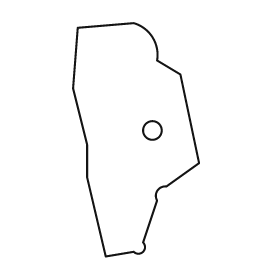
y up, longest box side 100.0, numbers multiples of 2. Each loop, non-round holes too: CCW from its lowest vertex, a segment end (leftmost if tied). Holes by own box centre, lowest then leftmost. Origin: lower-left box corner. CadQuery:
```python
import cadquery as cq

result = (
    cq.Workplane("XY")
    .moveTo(14.0, 0.0)
    .lineTo(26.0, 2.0)
    .threePointArc((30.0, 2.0), (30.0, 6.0))
    .lineTo(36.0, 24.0)
    .threePointArc((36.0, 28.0), (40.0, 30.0))
    .lineTo(54.0, 40.0)
    .lineTo(46.0, 78.0)
    .lineTo(36.0, 84.0)
    .threePointArc((34.0, 94.0), (26.0, 100.0))
    .lineTo(2.0, 98.0)
    .lineTo(0.0, 72.0)
    .lineTo(6.0, 48.0)
    .lineTo(6.0, 34.0)
    .close()
    .moveTo(34.0, 54.0)
    .circle(4.0)
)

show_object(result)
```